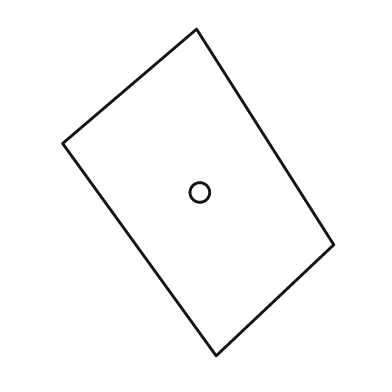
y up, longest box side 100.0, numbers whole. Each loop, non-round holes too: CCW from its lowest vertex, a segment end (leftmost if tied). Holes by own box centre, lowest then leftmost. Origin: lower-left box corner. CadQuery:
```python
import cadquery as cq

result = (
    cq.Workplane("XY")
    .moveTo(47.0, 0.0)
    .lineTo(83.0, 34.0)
    .lineTo(41.0, 100.0)
    .lineTo(0.0, 65.0)
    .close()
    .moveTo(42.0, 50.0)
    .circle(3.0)
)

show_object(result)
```